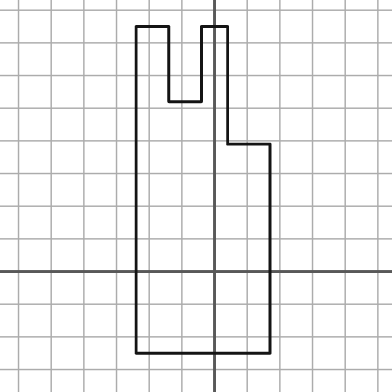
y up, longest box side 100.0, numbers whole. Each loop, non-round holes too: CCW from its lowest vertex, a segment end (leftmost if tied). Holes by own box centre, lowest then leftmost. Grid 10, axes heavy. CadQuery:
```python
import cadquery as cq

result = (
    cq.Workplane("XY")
    .moveTo(-24.0, -25.0)
    .lineTo(17.0, -25.0)
    .lineTo(17.0, 39.0)
    .lineTo(4.0, 39.0)
    .lineTo(4.0, 75.0)
    .lineTo(-4.0, 75.0)
    .lineTo(-4.0, 52.0)
    .lineTo(-14.0, 52.0)
    .lineTo(-14.0, 75.0)
    .lineTo(-24.0, 75.0)
    .close()
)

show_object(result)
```